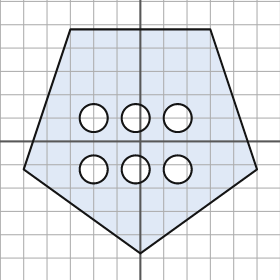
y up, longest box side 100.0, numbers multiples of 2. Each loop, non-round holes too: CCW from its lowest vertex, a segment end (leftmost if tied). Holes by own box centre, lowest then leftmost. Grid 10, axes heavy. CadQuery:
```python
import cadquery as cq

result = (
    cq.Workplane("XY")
    .moveTo(0.0, -48.0)
    .lineTo(50.0, -12.0)
    .lineTo(30.0, 48.0)
    .lineTo(-30.0, 48.0)
    .lineTo(-50.0, -12.0)
    .close()
    .moveTo(-20.0, -12.0)
    .circle(6.0)
    .moveTo(-2.0, -12.0)
    .circle(6.0)
    .moveTo(16.0, -12.0)
    .circle(6.0)
    .moveTo(-20.0, 10.0)
    .circle(6.0)
    .moveTo(-2.0, 10.0)
    .circle(6.0)
    .moveTo(16.0, 10.0)
    .circle(6.0)
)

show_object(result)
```